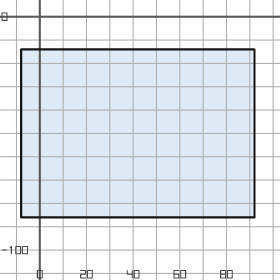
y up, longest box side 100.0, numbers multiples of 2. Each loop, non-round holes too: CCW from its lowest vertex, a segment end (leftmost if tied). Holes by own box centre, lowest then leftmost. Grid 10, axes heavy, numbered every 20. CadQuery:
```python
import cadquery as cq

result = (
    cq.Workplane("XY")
    .moveTo(-8.0, -86.0)
    .lineTo(92.0, -86.0)
    .lineTo(92.0, -14.0)
    .lineTo(-8.0, -14.0)
    .close()
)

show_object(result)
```